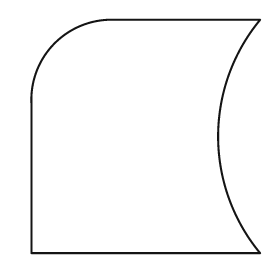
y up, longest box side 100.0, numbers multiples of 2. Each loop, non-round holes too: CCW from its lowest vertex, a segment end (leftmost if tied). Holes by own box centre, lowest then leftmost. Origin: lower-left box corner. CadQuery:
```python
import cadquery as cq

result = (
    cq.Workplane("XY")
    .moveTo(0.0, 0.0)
    .lineTo(98.0, 0.0)
    .threePointArc((80.0, 50.0), (98.0, 100.0))
    .lineTo(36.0, 100.0)
    .threePointArc((10.0, 90.0), (0.0, 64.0))
    .close()
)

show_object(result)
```